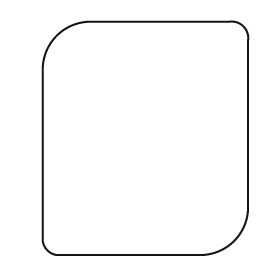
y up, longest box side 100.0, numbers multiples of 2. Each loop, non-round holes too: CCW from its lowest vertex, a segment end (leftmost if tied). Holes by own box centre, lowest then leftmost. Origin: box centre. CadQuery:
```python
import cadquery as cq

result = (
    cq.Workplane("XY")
    .moveTo(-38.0, -50.0)
    .lineTo(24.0, -50.0)
    .threePointArc((38.0, -44.0), (44.0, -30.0))
    .lineTo(44.0, 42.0)
    .threePointArc((42.0, 48.0), (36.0, 50.0))
    .lineTo(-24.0, 50.0)
    .threePointArc((-38.0, 44.0), (-44.0, 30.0))
    .lineTo(-44.0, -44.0)
    .threePointArc((-42.0, -48.0), (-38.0, -50.0))
    .close()
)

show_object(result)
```